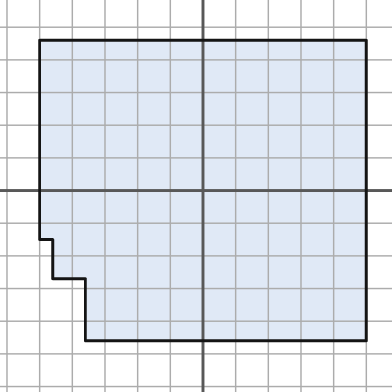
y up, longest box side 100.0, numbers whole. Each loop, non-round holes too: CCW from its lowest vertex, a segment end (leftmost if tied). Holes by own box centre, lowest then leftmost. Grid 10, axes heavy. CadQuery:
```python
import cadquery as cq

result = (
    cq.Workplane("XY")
    .moveTo(-36.0, -46.0)
    .lineTo(50.0, -46.0)
    .lineTo(50.0, 46.0)
    .lineTo(-50.0, 46.0)
    .lineTo(-50.0, -15.0)
    .lineTo(-46.0, -15.0)
    .lineTo(-46.0, -27.0)
    .lineTo(-36.0, -27.0)
    .close()
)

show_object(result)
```